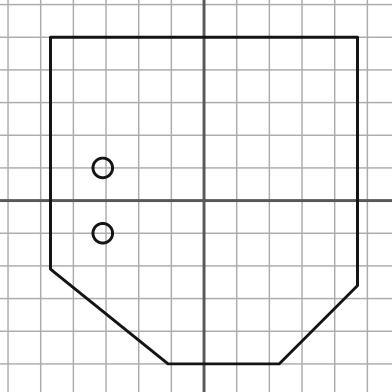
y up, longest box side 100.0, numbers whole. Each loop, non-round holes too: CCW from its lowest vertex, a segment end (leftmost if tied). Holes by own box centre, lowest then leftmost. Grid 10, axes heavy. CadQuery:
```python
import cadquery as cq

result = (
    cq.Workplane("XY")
    .moveTo(-11.0, -50.0)
    .lineTo(23.0, -50.0)
    .lineTo(47.0, -26.0)
    .lineTo(47.0, 50.0)
    .lineTo(-47.0, 50.0)
    .lineTo(-47.0, -21.0)
    .close()
    .moveTo(-31.0, -10.0)
    .circle(3.0)
    .moveTo(-31.0, 10.0)
    .circle(3.0)
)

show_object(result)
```